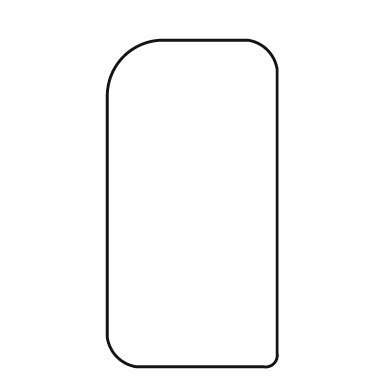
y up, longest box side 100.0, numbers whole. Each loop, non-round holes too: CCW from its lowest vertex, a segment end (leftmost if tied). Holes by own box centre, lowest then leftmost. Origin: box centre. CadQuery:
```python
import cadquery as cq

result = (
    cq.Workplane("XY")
    .moveTo(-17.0, -50.0)
    .lineTo(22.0, -50.0)
    .threePointArc((25.0, -49.0), (26.0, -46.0))
    .lineTo(26.0, 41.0)
    .threePointArc((23.0, 47.0), (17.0, 50.0))
    .lineTo(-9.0, 50.0)
    .threePointArc((-21.0, 45.0), (-26.0, 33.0))
    .lineTo(-26.0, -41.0)
    .threePointArc((-23.0, -47.0), (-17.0, -50.0))
    .close()
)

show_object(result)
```